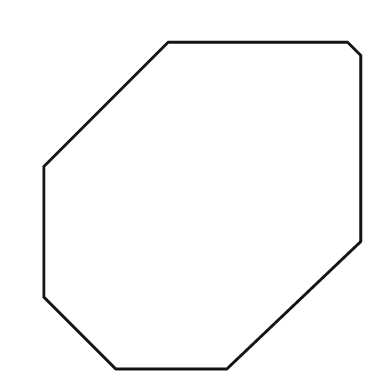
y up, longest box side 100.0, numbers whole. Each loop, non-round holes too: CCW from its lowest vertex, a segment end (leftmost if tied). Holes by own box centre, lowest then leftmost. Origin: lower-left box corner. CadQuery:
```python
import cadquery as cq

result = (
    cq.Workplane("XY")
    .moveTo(22.0, 0.0)
    .lineTo(56.0, 0.0)
    .lineTo(97.0, 39.0)
    .lineTo(97.0, 96.0)
    .lineTo(93.0, 100.0)
    .lineTo(38.0, 100.0)
    .lineTo(0.0, 62.0)
    .lineTo(0.0, 22.0)
    .close()
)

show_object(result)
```